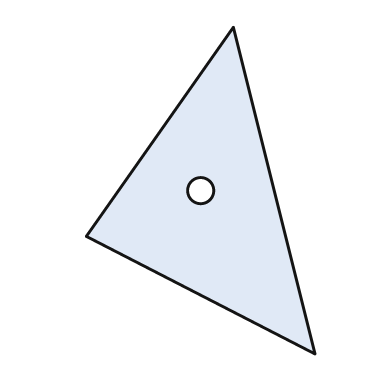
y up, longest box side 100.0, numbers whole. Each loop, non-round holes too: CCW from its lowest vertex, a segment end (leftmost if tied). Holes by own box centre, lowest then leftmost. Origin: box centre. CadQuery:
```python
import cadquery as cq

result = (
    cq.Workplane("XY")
    .moveTo(35.0, -50.0)
    .lineTo(10.0, 50.0)
    .lineTo(-35.0, -14.0)
    .close()
    .moveTo(0.0, 0.0)
    .circle(4.0)
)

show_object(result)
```